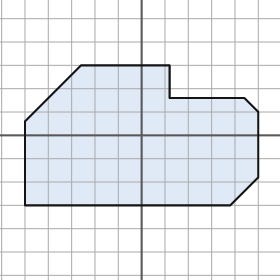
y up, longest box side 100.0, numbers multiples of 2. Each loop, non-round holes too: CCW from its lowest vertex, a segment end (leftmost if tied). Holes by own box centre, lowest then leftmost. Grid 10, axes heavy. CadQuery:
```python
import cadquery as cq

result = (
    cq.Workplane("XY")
    .moveTo(-50.0, -30.0)
    .lineTo(38.0, -30.0)
    .lineTo(50.0, -18.0)
    .lineTo(50.0, 10.0)
    .lineTo(44.0, 16.0)
    .lineTo(12.0, 16.0)
    .lineTo(12.0, 30.0)
    .lineTo(-26.0, 30.0)
    .lineTo(-50.0, 6.0)
    .close()
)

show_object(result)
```